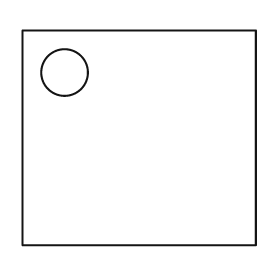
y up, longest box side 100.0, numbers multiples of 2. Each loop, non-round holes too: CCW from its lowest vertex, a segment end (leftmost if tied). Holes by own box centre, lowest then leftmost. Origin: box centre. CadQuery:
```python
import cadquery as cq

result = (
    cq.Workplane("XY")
    .moveTo(-50.0, -46.0)
    .lineTo(50.0, -46.0)
    .lineTo(50.0, 46.0)
    .lineTo(-50.0, 46.0)
    .close()
    .moveTo(-32.0, 28.0)
    .circle(10.0)
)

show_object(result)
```